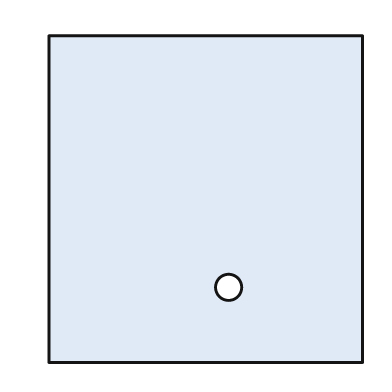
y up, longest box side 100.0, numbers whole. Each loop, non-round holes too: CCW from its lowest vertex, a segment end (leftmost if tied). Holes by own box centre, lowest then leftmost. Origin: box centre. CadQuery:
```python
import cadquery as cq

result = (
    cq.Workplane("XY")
    .moveTo(-48.0, -50.0)
    .lineTo(48.0, -50.0)
    .lineTo(48.0, 50.0)
    .lineTo(-48.0, 50.0)
    .close()
    .moveTo(7.0, -27.0)
    .circle(4.0)
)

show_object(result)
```